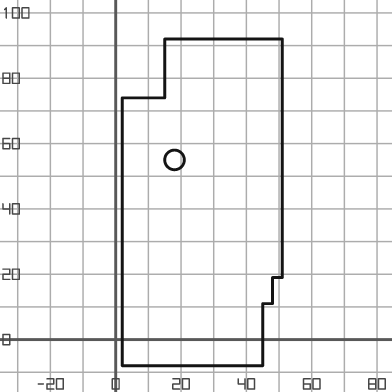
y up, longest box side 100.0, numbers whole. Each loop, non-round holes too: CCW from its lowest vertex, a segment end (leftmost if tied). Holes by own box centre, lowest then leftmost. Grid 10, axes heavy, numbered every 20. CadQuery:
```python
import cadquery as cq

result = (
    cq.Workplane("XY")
    .moveTo(2.0, -8.0)
    .lineTo(45.0, -8.0)
    .lineTo(45.0, 11.0)
    .lineTo(48.0, 11.0)
    .lineTo(48.0, 19.0)
    .lineTo(51.0, 19.0)
    .lineTo(51.0, 92.0)
    .lineTo(15.0, 92.0)
    .lineTo(15.0, 74.0)
    .lineTo(2.0, 74.0)
    .close()
    .moveTo(18.0, 55.0)
    .circle(3.0)
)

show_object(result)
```